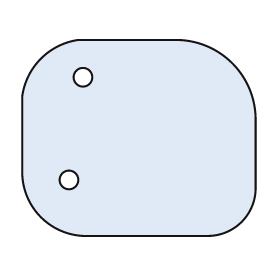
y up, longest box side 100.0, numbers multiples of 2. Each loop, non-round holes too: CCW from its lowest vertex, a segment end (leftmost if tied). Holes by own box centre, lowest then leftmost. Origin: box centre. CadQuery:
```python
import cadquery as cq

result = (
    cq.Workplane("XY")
    .moveTo(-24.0, -42.0)
    .lineTo(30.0, -42.0)
    .threePointArc((44.0, -36.0), (50.0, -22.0))
    .lineTo(50.0, 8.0)
    .threePointArc((40.0, 32.0), (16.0, 42.0))
    .lineTo(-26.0, 42.0)
    .threePointArc((-42.0, 34.0), (-50.0, 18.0))
    .lineTo(-50.0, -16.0)
    .threePointArc((-42.0, -34.0), (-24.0, -42.0))
    .close()
    .moveTo(-30.0, -18.0)
    .circle(4.0)
    .moveTo(-24.0, 26.0)
    .circle(4.0)
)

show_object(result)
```